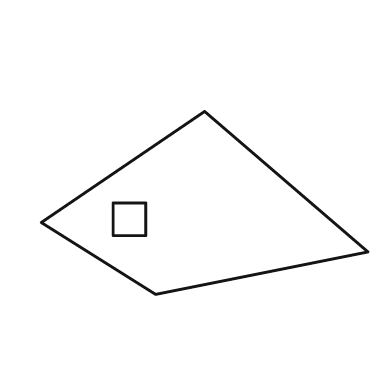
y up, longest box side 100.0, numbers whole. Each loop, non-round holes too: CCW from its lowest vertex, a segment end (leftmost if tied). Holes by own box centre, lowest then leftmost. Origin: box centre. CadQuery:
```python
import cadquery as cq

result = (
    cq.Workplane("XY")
    .moveTo(-15.0, -28.0)
    .lineTo(50.0, -15.0)
    .lineTo(0.0, 28.0)
    .lineTo(-50.0, -6.0)
    .close()
    .moveTo(-28.0, -10.0)
    .lineTo(-18.0, -10.0)
    .lineTo(-18.0, 0.0)
    .lineTo(-28.0, 0.0)
    .close()
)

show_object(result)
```